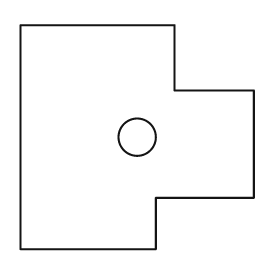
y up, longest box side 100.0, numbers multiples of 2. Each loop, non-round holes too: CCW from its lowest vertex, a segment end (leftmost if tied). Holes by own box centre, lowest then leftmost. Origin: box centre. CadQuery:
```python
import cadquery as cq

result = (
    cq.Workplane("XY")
    .moveTo(-50.0, -48.0)
    .lineTo(8.0, -48.0)
    .lineTo(8.0, -26.0)
    .lineTo(50.0, -26.0)
    .lineTo(50.0, 20.0)
    .lineTo(16.0, 20.0)
    .lineTo(16.0, 48.0)
    .lineTo(-50.0, 48.0)
    .close()
    .moveTo(0.0, 0.0)
    .circle(8.0)
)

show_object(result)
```